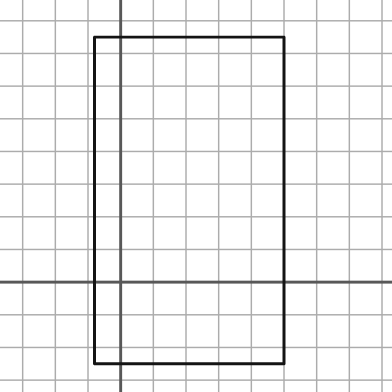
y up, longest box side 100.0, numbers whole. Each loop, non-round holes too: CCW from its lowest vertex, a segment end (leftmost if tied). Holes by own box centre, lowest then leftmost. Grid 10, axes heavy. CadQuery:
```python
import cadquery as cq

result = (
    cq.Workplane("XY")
    .moveTo(-8.0, -25.0)
    .lineTo(50.0, -25.0)
    .lineTo(50.0, 75.0)
    .lineTo(-8.0, 75.0)
    .close()
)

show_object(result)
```